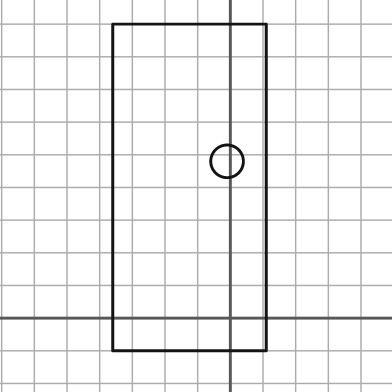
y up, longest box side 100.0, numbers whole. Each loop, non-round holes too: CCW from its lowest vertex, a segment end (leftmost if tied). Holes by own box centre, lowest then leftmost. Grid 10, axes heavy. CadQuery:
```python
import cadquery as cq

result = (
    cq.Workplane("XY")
    .moveTo(-36.0, -10.0)
    .lineTo(11.0, -10.0)
    .lineTo(11.0, 90.0)
    .lineTo(-36.0, 90.0)
    .close()
    .moveTo(-1.0, 48.0)
    .circle(5.0)
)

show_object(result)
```